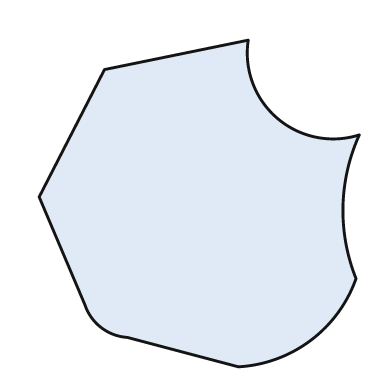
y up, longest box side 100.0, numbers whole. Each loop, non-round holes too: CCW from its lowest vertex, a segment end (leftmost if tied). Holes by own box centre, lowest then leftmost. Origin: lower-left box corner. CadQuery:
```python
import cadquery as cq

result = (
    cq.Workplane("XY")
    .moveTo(61.0, 0.0)
    .threePointArc((83.0, 8.0), (97.0, 27.0))
    .threePointArc((93.0, 49.0), (98.0, 71.0))
    .threePointArc((73.0, 76.0), (64.0, 100.0))
    .lineTo(20.0, 91.0)
    .lineTo(0.0, 52.0)
    .lineTo(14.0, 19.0)
    .threePointArc((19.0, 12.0), (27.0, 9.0))
    .close()
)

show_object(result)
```